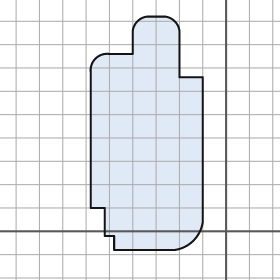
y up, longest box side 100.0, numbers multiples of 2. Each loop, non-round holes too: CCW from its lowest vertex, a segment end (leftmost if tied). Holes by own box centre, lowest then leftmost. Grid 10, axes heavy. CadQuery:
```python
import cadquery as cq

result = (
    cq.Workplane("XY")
    .moveTo(-48.0, -8.0)
    .lineTo(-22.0, -8.0)
    .threePointArc((-14.0, -4.0), (-10.0, 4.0))
    .lineTo(-10.0, 66.0)
    .lineTo(-20.0, 66.0)
    .lineTo(-20.0, 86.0)
    .threePointArc((-22.0, 90.0), (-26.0, 92.0))
    .lineTo(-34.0, 92.0)
    .threePointArc((-38.0, 90.0), (-40.0, 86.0))
    .lineTo(-40.0, 76.0)
    .lineTo(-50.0, 76.0)
    .threePointArc((-56.0, 74.0), (-58.0, 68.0))
    .lineTo(-58.0, 10.0)
    .lineTo(-52.0, 10.0)
    .lineTo(-52.0, -2.0)
    .lineTo(-48.0, -2.0)
    .close()
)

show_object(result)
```